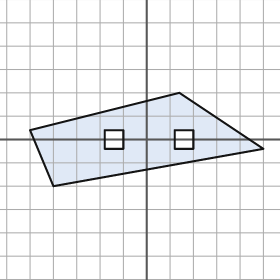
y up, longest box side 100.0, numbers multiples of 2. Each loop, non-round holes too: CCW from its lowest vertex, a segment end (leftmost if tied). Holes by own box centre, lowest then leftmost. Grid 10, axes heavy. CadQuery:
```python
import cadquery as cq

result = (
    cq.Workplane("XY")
    .moveTo(-40.0, -20.0)
    .lineTo(50.0, -4.0)
    .lineTo(14.0, 20.0)
    .lineTo(-50.0, 4.0)
    .close()
    .moveTo(-18.0, -4.0)
    .lineTo(-10.0, -4.0)
    .lineTo(-10.0, 4.0)
    .lineTo(-18.0, 4.0)
    .close()
    .moveTo(12.0, -4.0)
    .lineTo(20.0, -4.0)
    .lineTo(20.0, 4.0)
    .lineTo(12.0, 4.0)
    .close()
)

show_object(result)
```